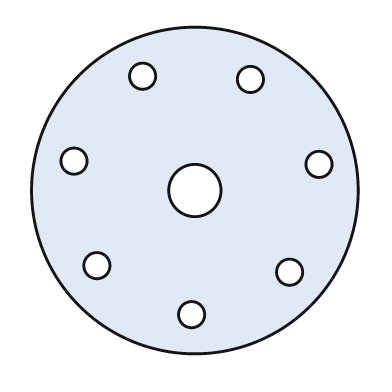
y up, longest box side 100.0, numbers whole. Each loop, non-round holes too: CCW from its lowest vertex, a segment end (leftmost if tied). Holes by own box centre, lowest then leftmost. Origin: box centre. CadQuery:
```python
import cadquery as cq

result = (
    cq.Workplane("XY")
    .moveTo(0.0, 0.0)
    .circle(50.0)
    .moveTo(-1.0, -38.0)
    .circle(4.0)
    .moveTo(29.0, -25.0)
    .circle(4.0)
    .moveTo(-30.0, -23.0)
    .circle(4.0)
    .moveTo(0.0, 0.0)
    .circle(8.0)
    .moveTo(38.0, 8.0)
    .circle(4.0)
    .moveTo(-37.0, 9.0)
    .circle(4.0)
    .moveTo(17.0, 34.0)
    .circle(4.0)
    .moveTo(-16.0, 35.0)
    .circle(4.0)
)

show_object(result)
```